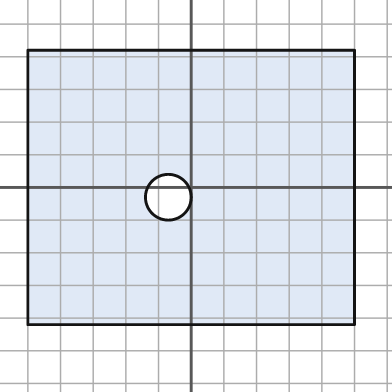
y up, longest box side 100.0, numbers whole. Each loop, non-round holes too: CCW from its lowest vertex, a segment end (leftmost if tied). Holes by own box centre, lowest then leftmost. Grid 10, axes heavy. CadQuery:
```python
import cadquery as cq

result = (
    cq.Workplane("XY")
    .moveTo(-50.0, -42.0)
    .lineTo(50.0, -42.0)
    .lineTo(50.0, 42.0)
    .lineTo(-50.0, 42.0)
    .close()
    .moveTo(-7.0, -3.0)
    .circle(7.0)
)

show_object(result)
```